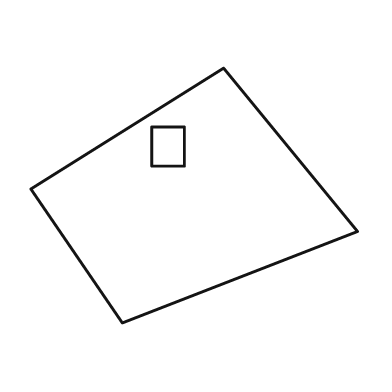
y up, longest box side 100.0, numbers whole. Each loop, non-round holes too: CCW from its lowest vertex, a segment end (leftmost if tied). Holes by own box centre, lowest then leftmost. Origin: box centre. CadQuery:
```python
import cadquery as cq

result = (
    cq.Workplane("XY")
    .moveTo(-22.0, -39.0)
    .lineTo(50.0, -11.0)
    .lineTo(9.0, 39.0)
    .lineTo(-50.0, 2.0)
    .close()
    .moveTo(-13.0, 9.0)
    .lineTo(-3.0, 9.0)
    .lineTo(-3.0, 21.0)
    .lineTo(-13.0, 21.0)
    .close()
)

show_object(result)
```